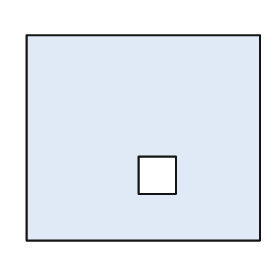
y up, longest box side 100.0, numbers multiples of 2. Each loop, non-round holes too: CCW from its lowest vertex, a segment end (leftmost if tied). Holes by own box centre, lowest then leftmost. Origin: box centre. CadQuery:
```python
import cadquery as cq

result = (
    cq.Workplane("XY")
    .moveTo(-50.0, -44.0)
    .lineTo(50.0, -44.0)
    .lineTo(50.0, 44.0)
    .lineTo(-50.0, 44.0)
    .close()
    .moveTo(-2.0, -24.0)
    .lineTo(14.0, -24.0)
    .lineTo(14.0, -8.0)
    .lineTo(-2.0, -8.0)
    .close()
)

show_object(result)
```